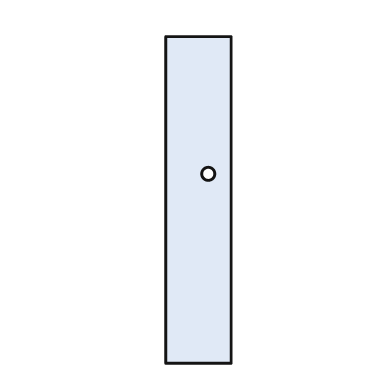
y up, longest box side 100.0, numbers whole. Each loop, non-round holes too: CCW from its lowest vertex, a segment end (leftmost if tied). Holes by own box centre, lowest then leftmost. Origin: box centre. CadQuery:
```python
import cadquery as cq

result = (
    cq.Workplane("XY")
    .moveTo(-10.0, -50.0)
    .lineTo(10.0, -50.0)
    .lineTo(10.0, 50.0)
    .lineTo(-10.0, 50.0)
    .close()
    .moveTo(3.0, 8.0)
    .circle(2.0)
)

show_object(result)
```